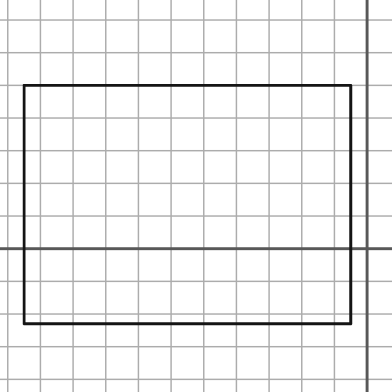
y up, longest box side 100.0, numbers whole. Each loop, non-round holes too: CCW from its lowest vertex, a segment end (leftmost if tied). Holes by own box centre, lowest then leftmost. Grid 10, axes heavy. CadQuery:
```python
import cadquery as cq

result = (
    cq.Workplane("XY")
    .moveTo(-105.0, -23.0)
    .lineTo(-5.0, -23.0)
    .lineTo(-5.0, 50.0)
    .lineTo(-105.0, 50.0)
    .close()
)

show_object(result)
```